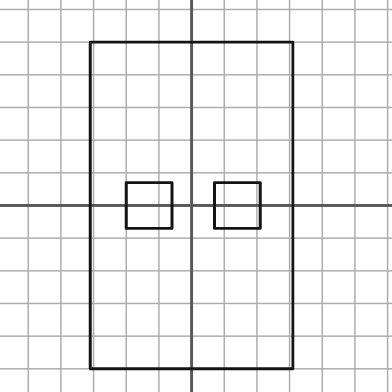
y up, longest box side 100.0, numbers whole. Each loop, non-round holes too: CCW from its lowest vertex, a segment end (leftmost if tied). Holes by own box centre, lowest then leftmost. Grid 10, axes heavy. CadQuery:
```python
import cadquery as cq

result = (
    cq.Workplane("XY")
    .moveTo(-31.0, -50.0)
    .lineTo(31.0, -50.0)
    .lineTo(31.0, 50.0)
    .lineTo(-31.0, 50.0)
    .close()
    .moveTo(-20.0, -7.0)
    .lineTo(-6.0, -7.0)
    .lineTo(-6.0, 7.0)
    .lineTo(-20.0, 7.0)
    .close()
    .moveTo(7.0, -7.0)
    .lineTo(21.0, -7.0)
    .lineTo(21.0, 7.0)
    .lineTo(7.0, 7.0)
    .close()
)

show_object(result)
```